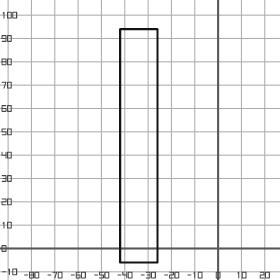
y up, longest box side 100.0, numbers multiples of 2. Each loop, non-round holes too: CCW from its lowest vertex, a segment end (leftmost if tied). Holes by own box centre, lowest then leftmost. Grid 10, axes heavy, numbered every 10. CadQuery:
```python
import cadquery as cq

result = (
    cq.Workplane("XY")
    .moveTo(-42.0, -6.0)
    .lineTo(-26.0, -6.0)
    .lineTo(-26.0, 94.0)
    .lineTo(-42.0, 94.0)
    .close()
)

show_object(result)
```